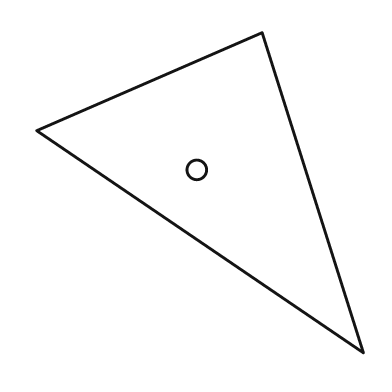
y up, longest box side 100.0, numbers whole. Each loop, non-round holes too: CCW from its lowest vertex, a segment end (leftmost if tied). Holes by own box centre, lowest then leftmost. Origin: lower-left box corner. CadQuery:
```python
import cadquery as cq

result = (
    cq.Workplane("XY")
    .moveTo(100.0, 0.0)
    .lineTo(69.0, 98.0)
    .lineTo(0.0, 68.0)
    .close()
    .moveTo(49.0, 56.0)
    .circle(3.0)
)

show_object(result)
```